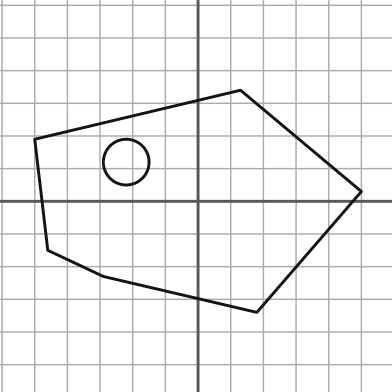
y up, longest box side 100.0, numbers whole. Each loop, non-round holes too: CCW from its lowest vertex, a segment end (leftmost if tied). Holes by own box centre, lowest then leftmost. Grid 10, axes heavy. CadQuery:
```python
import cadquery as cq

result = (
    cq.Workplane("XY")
    .moveTo(18.0, -34.0)
    .lineTo(50.0, 3.0)
    .lineTo(13.0, 34.0)
    .lineTo(-50.0, 19.0)
    .lineTo(-46.0, -15.0)
    .lineTo(-29.0, -23.0)
    .close()
    .moveTo(-22.0, 12.0)
    .circle(7.0)
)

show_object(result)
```